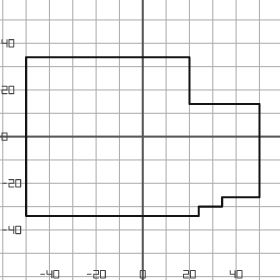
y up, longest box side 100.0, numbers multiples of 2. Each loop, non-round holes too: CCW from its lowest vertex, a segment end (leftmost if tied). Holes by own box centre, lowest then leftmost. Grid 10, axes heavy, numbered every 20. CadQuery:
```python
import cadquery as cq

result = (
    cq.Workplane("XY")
    .moveTo(-50.0, -34.0)
    .lineTo(24.0, -34.0)
    .lineTo(24.0, -30.0)
    .lineTo(34.0, -30.0)
    .lineTo(34.0, -26.0)
    .lineTo(50.0, -26.0)
    .lineTo(50.0, 14.0)
    .lineTo(20.0, 14.0)
    .lineTo(20.0, 34.0)
    .lineTo(-50.0, 34.0)
    .close()
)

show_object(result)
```